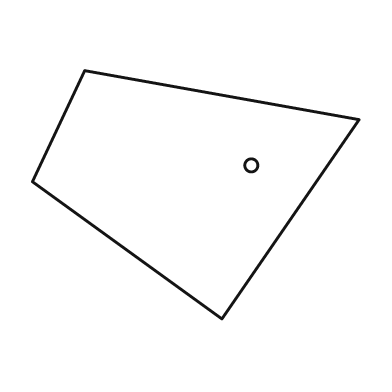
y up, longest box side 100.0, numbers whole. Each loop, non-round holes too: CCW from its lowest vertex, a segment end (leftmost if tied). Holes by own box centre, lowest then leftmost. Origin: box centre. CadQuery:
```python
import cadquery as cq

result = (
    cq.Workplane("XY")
    .moveTo(8.0, -38.0)
    .lineTo(50.0, 23.0)
    .lineTo(-34.0, 38.0)
    .lineTo(-50.0, 4.0)
    .close()
    .moveTo(17.0, 9.0)
    .circle(2.0)
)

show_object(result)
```